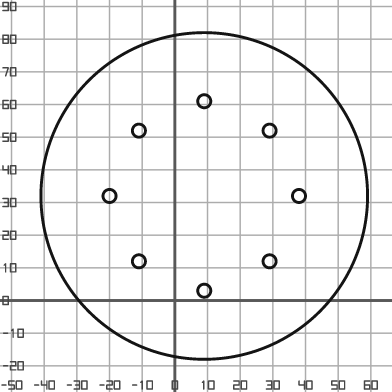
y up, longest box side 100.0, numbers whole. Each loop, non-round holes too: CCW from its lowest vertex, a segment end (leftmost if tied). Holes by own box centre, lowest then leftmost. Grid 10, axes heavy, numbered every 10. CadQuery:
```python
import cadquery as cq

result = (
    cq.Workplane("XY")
    .moveTo(9.0, 32.0)
    .circle(50.0)
    .moveTo(9.0, 3.0)
    .circle(2.0)
    .moveTo(-11.0, 12.0)
    .circle(2.0)
    .moveTo(29.0, 12.0)
    .circle(2.0)
    .moveTo(-20.0, 32.0)
    .circle(2.0)
    .moveTo(38.0, 32.0)
    .circle(2.0)
    .moveTo(-11.0, 52.0)
    .circle(2.0)
    .moveTo(29.0, 52.0)
    .circle(2.0)
    .moveTo(9.0, 61.0)
    .circle(2.0)
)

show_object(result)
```